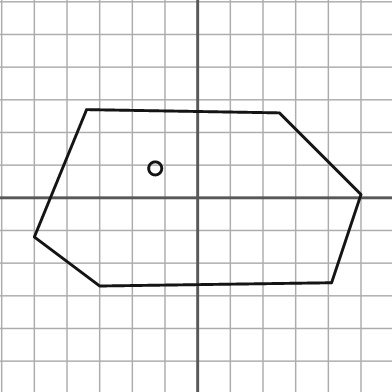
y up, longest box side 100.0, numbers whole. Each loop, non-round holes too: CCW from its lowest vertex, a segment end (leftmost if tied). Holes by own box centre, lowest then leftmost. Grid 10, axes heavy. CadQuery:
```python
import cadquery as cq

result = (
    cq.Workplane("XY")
    .moveTo(-30.0, -27.0)
    .lineTo(41.0, -26.0)
    .lineTo(50.0, 1.0)
    .lineTo(25.0, 26.0)
    .lineTo(-34.0, 27.0)
    .lineTo(-50.0, -12.0)
    .close()
    .moveTo(-13.0, 9.0)
    .circle(2.0)
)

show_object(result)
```